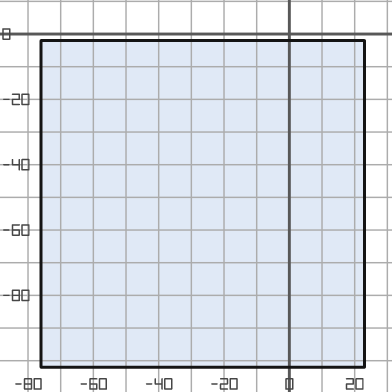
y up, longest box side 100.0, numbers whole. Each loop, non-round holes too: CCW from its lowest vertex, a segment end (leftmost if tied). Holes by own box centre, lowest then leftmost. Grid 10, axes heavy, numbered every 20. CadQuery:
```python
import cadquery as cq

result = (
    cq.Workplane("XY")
    .moveTo(-76.0, -102.0)
    .lineTo(23.0, -102.0)
    .lineTo(23.0, -2.0)
    .lineTo(-76.0, -2.0)
    .close()
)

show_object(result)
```